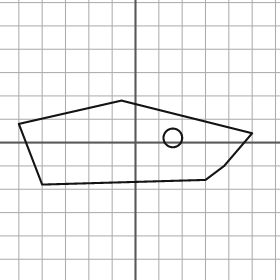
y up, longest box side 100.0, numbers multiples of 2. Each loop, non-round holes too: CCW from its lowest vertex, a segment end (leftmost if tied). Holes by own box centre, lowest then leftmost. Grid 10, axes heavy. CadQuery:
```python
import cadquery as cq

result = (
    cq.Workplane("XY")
    .moveTo(-40.0, -18.0)
    .lineTo(30.0, -16.0)
    .lineTo(38.0, -10.0)
    .lineTo(50.0, 4.0)
    .lineTo(-6.0, 18.0)
    .lineTo(-50.0, 8.0)
    .close()
    .moveTo(16.0, 2.0)
    .circle(4.0)
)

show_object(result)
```